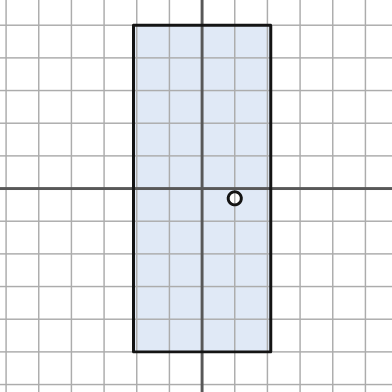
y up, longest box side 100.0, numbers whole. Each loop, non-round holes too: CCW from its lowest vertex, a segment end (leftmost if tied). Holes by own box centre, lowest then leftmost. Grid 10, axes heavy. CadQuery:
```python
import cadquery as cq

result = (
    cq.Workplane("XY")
    .moveTo(-21.0, -50.0)
    .lineTo(21.0, -50.0)
    .lineTo(21.0, 50.0)
    .lineTo(-21.0, 50.0)
    .close()
    .moveTo(10.0, -3.0)
    .circle(2.0)
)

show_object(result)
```